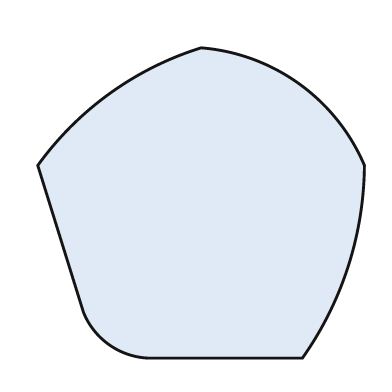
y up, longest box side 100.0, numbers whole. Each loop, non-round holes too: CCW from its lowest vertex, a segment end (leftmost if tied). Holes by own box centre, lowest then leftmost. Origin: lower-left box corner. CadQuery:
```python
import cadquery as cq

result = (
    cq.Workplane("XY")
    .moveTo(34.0, 0.0)
    .lineTo(81.0, 0.0)
    .threePointArc((95.0, 28.0), (100.0, 59.0))
    .threePointArc((80.0, 84.0), (50.0, 95.0))
    .threePointArc((22.0, 81.0), (0.0, 59.0))
    .lineTo(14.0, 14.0)
    .threePointArc((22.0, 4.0), (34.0, 0.0))
    .close()
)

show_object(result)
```